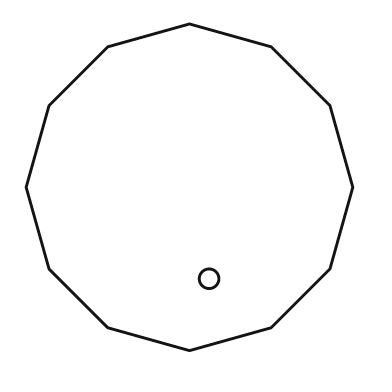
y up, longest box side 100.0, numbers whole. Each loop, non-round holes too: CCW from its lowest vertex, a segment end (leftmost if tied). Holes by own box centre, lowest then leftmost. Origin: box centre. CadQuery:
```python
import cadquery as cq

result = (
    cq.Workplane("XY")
    .moveTo(0.0, -50.0)
    .lineTo(25.0, -43.0)
    .lineTo(43.0, -25.0)
    .lineTo(50.0, 0.0)
    .lineTo(43.0, 25.0)
    .lineTo(25.0, 43.0)
    .lineTo(0.0, 50.0)
    .lineTo(-25.0, 43.0)
    .lineTo(-43.0, 25.0)
    .lineTo(-50.0, 0.0)
    .lineTo(-43.0, -25.0)
    .lineTo(-25.0, -43.0)
    .close()
    .moveTo(6.0, -28.0)
    .circle(3.0)
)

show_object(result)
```